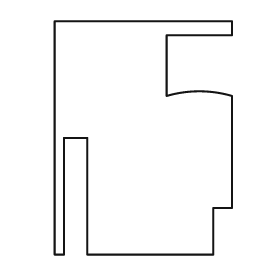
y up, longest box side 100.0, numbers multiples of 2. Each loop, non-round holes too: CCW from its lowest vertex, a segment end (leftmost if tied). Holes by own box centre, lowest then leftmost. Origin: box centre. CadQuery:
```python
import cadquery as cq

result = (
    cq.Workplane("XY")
    .moveTo(-38.0, -50.0)
    .lineTo(-34.0, -50.0)
    .lineTo(-34.0, 0.0)
    .lineTo(-24.0, 0.0)
    .lineTo(-24.0, -50.0)
    .lineTo(30.0, -50.0)
    .lineTo(30.0, -30.0)
    .lineTo(38.0, -30.0)
    .lineTo(38.0, 18.0)
    .threePointArc((24.0, 20.0), (10.0, 18.0))
    .lineTo(10.0, 44.0)
    .lineTo(38.0, 44.0)
    .lineTo(38.0, 50.0)
    .lineTo(-38.0, 50.0)
    .close()
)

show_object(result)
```